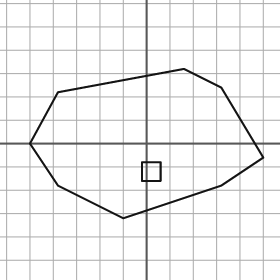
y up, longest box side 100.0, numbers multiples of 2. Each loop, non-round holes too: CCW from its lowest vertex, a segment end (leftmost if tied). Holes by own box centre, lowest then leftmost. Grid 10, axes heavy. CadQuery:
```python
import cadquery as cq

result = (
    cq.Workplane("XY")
    .moveTo(-10.0, -32.0)
    .lineTo(32.0, -18.0)
    .lineTo(50.0, -6.0)
    .lineTo(32.0, 24.0)
    .lineTo(16.0, 32.0)
    .lineTo(-38.0, 22.0)
    .lineTo(-50.0, 0.0)
    .lineTo(-38.0, -18.0)
    .close()
    .moveTo(-2.0, -16.0)
    .lineTo(6.0, -16.0)
    .lineTo(6.0, -8.0)
    .lineTo(-2.0, -8.0)
    .close()
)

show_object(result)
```